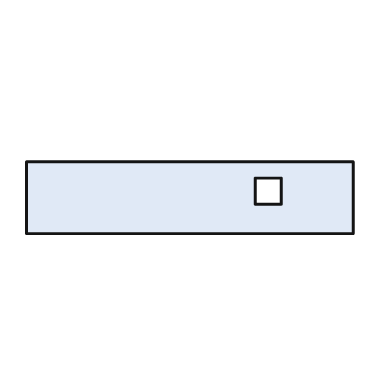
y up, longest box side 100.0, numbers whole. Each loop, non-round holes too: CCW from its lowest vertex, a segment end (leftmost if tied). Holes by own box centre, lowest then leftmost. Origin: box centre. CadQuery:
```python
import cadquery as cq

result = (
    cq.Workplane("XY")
    .moveTo(-50.0, -11.0)
    .lineTo(50.0, -11.0)
    .lineTo(50.0, 11.0)
    .lineTo(-50.0, 11.0)
    .close()
    .moveTo(20.0, -2.0)
    .lineTo(28.0, -2.0)
    .lineTo(28.0, 6.0)
    .lineTo(20.0, 6.0)
    .close()
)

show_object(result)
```